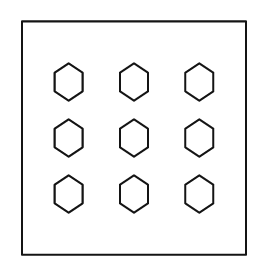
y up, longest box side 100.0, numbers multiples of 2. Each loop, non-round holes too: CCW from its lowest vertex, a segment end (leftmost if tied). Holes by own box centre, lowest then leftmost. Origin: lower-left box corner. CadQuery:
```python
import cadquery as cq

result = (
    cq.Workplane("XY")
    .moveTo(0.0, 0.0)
    .lineTo(96.0, 0.0)
    .lineTo(96.0, 100.0)
    .lineTo(0.0, 100.0)
    .close()
    .moveTo(20.0, 18.0)
    .lineTo(26.0, 22.0)
    .lineTo(26.0, 30.0)
    .lineTo(20.0, 34.0)
    .lineTo(14.0, 30.0)
    .lineTo(14.0, 22.0)
    .close()
    .moveTo(48.0, 18.0)
    .lineTo(54.0, 22.0)
    .lineTo(54.0, 30.0)
    .lineTo(48.0, 34.0)
    .lineTo(42.0, 30.0)
    .lineTo(42.0, 22.0)
    .close()
    .moveTo(76.0, 18.0)
    .lineTo(82.0, 22.0)
    .lineTo(82.0, 30.0)
    .lineTo(76.0, 34.0)
    .lineTo(70.0, 30.0)
    .lineTo(70.0, 22.0)
    .close()
    .moveTo(20.0, 42.0)
    .lineTo(26.0, 46.0)
    .lineTo(26.0, 54.0)
    .lineTo(20.0, 58.0)
    .lineTo(14.0, 54.0)
    .lineTo(14.0, 46.0)
    .close()
    .moveTo(48.0, 42.0)
    .lineTo(54.0, 46.0)
    .lineTo(54.0, 54.0)
    .lineTo(48.0, 58.0)
    .lineTo(42.0, 54.0)
    .lineTo(42.0, 46.0)
    .close()
    .moveTo(76.0, 42.0)
    .lineTo(82.0, 46.0)
    .lineTo(82.0, 54.0)
    .lineTo(76.0, 58.0)
    .lineTo(70.0, 54.0)
    .lineTo(70.0, 46.0)
    .close()
    .moveTo(20.0, 66.0)
    .lineTo(26.0, 70.0)
    .lineTo(26.0, 78.0)
    .lineTo(20.0, 82.0)
    .lineTo(14.0, 78.0)
    .lineTo(14.0, 70.0)
    .close()
    .moveTo(48.0, 66.0)
    .lineTo(54.0, 70.0)
    .lineTo(54.0, 78.0)
    .lineTo(48.0, 82.0)
    .lineTo(42.0, 78.0)
    .lineTo(42.0, 70.0)
    .close()
    .moveTo(76.0, 66.0)
    .lineTo(82.0, 70.0)
    .lineTo(82.0, 78.0)
    .lineTo(76.0, 82.0)
    .lineTo(70.0, 78.0)
    .lineTo(70.0, 70.0)
    .close()
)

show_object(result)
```